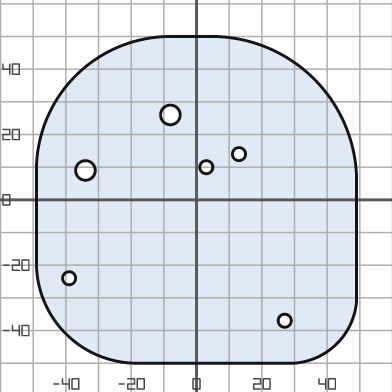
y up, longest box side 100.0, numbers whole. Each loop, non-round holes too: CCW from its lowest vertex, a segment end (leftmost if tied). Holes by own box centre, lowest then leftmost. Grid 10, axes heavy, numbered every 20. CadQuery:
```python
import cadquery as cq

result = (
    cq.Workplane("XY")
    .moveTo(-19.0, -50.0)
    .lineTo(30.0, -50.0)
    .threePointArc((43.0, -44.0), (49.0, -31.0))
    .lineTo(49.0, 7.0)
    .threePointArc((36.0, 37.0), (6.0, 50.0))
    .lineTo(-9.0, 50.0)
    .threePointArc((-37.0, 38.0), (-49.0, 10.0))
    .lineTo(-49.0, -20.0)
    .threePointArc((-40.0, -41.0), (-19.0, -50.0))
    .close()
    .moveTo(27.0, -37.0)
    .circle(2.0)
    .moveTo(-39.0, -24.0)
    .circle(2.0)
    .moveTo(-34.0, 9.0)
    .circle(3.0)
    .moveTo(3.0, 10.0)
    .circle(2.0)
    .moveTo(13.0, 14.0)
    .circle(2.0)
    .moveTo(-8.0, 26.0)
    .circle(3.0)
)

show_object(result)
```